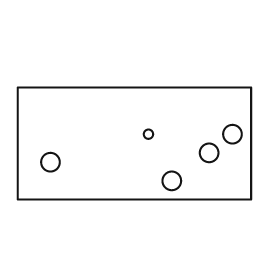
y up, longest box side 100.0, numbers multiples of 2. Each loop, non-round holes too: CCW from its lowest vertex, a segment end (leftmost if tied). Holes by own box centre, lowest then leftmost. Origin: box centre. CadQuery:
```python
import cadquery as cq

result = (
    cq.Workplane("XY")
    .moveTo(-50.0, -24.0)
    .lineTo(50.0, -24.0)
    .lineTo(50.0, 24.0)
    .lineTo(-50.0, 24.0)
    .close()
    .moveTo(16.0, -16.0)
    .circle(4.0)
    .moveTo(-36.0, -8.0)
    .circle(4.0)
    .moveTo(32.0, -4.0)
    .circle(4.0)
    .moveTo(6.0, 4.0)
    .circle(2.0)
    .moveTo(42.0, 4.0)
    .circle(4.0)
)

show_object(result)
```